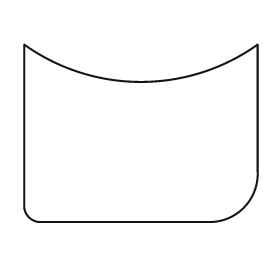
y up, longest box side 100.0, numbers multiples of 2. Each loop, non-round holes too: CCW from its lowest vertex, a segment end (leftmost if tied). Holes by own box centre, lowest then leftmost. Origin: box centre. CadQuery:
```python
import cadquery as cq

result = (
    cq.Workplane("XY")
    .moveTo(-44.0, -38.0)
    .lineTo(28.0, -38.0)
    .threePointArc((44.0, -32.0), (50.0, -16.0))
    .lineTo(50.0, 38.0)
    .threePointArc((0.0, 22.0), (-50.0, 38.0))
    .lineTo(-50.0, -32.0)
    .threePointArc((-48.0, -36.0), (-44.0, -38.0))
    .close()
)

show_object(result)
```